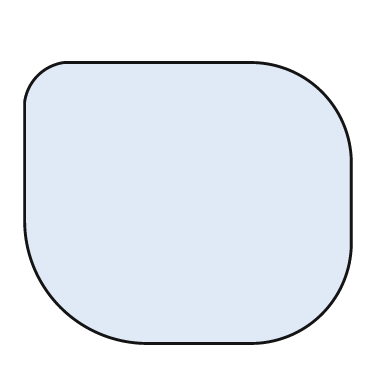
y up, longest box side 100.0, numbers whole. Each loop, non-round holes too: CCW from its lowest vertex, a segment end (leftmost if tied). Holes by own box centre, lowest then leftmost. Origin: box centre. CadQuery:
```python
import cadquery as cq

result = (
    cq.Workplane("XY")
    .moveTo(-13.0, -43.0)
    .lineTo(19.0, -43.0)
    .threePointArc((41.0, -34.0), (50.0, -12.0))
    .lineTo(50.0, 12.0)
    .threePointArc((41.0, 34.0), (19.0, 43.0))
    .lineTo(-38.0, 43.0)
    .threePointArc((-46.0, 39.0), (-50.0, 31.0))
    .lineTo(-50.0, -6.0)
    .threePointArc((-39.0, -32.0), (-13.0, -43.0))
    .close()
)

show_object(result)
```